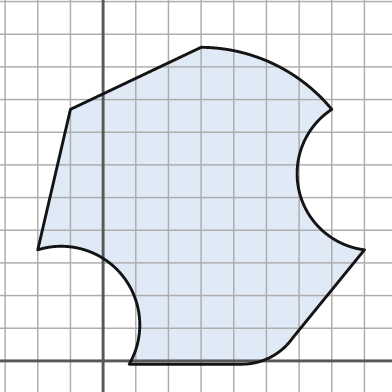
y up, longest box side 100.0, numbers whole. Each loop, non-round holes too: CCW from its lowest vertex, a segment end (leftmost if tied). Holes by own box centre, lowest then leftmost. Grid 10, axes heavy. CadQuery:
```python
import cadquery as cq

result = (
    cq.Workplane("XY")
    .moveTo(8.0, -1.0)
    .lineTo(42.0, -1.0)
    .threePointArc((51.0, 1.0), (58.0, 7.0))
    .lineTo(80.0, 34.0)
    .threePointArc((60.0, 52.0), (70.0, 77.0))
    .threePointArc((52.0, 91.0), (30.0, 96.0))
    .lineTo(-10.0, 77.0)
    .lineTo(-20.0, 34.0)
    .threePointArc((6.0, 26.0), (8.0, -1.0))
    .close()
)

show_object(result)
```